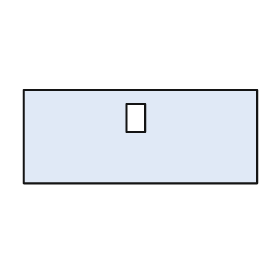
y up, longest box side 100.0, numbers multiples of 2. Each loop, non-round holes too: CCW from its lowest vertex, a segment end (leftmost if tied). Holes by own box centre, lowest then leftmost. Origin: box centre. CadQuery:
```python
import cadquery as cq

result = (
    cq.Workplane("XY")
    .moveTo(-50.0, -20.0)
    .lineTo(50.0, -20.0)
    .lineTo(50.0, 20.0)
    .lineTo(-50.0, 20.0)
    .close()
    .moveTo(-6.0, 2.0)
    .lineTo(2.0, 2.0)
    .lineTo(2.0, 14.0)
    .lineTo(-6.0, 14.0)
    .close()
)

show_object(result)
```